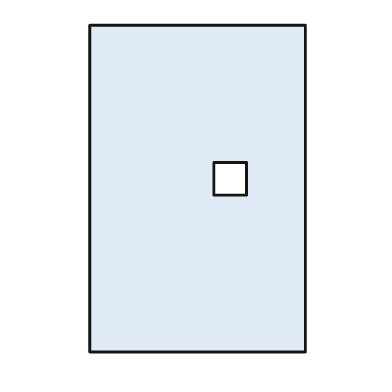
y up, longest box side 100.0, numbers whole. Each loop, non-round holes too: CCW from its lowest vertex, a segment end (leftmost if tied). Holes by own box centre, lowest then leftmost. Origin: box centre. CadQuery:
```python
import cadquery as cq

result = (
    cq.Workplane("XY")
    .moveTo(-33.0, -50.0)
    .lineTo(33.0, -50.0)
    .lineTo(33.0, 50.0)
    .lineTo(-33.0, 50.0)
    .close()
    .moveTo(5.0, -2.0)
    .lineTo(15.0, -2.0)
    .lineTo(15.0, 8.0)
    .lineTo(5.0, 8.0)
    .close()
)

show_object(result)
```